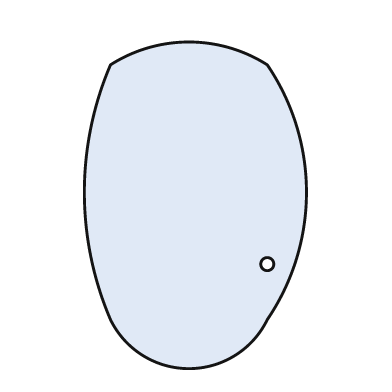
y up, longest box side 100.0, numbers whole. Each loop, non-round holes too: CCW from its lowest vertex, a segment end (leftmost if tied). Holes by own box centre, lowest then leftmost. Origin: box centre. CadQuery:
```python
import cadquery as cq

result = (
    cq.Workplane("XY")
    .moveTo(-26.0, -35.0)
    .threePointArc((-2.0, -50.0), (22.0, -35.0))
    .threePointArc((34.0, 4.0), (22.0, 43.0))
    .threePointArc((-2.0, 50.0), (-26.0, 43.0))
    .threePointArc((-34.0, 4.0), (-26.0, -35.0))
    .close()
    .moveTo(22.0, -18.0)
    .circle(2.0)
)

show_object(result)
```